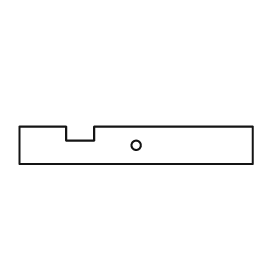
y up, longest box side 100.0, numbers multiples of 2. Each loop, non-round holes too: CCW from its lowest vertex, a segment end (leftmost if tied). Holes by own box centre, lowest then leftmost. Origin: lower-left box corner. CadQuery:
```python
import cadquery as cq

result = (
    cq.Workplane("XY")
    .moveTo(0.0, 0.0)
    .lineTo(100.0, 0.0)
    .lineTo(100.0, 16.0)
    .lineTo(32.0, 16.0)
    .lineTo(32.0, 10.0)
    .lineTo(20.0, 10.0)
    .lineTo(20.0, 16.0)
    .lineTo(0.0, 16.0)
    .close()
    .moveTo(50.0, 8.0)
    .circle(2.0)
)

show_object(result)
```